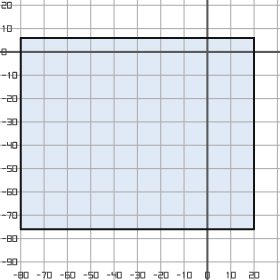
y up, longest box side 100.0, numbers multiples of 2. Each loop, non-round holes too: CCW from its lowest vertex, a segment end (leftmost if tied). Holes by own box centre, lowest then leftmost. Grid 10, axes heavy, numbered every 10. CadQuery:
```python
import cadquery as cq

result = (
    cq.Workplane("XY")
    .moveTo(-80.0, -76.0)
    .lineTo(20.0, -76.0)
    .lineTo(20.0, 6.0)
    .lineTo(-80.0, 6.0)
    .close()
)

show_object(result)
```